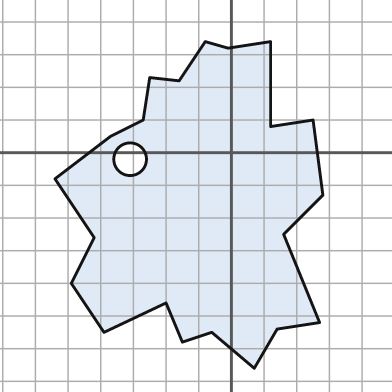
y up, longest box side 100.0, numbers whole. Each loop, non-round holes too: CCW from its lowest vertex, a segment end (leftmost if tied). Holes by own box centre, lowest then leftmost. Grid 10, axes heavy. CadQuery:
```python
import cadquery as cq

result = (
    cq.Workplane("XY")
    .moveTo(7.0, -66.0)
    .lineTo(14.0, -54.0)
    .lineTo(27.0, -52.0)
    .lineTo(16.0, -25.0)
    .lineTo(28.0, -13.0)
    .lineTo(25.0, 10.0)
    .lineTo(12.0, 8.0)
    .lineTo(12.0, 34.0)
    .lineTo(-1.0, 32.0)
    .lineTo(-8.0, 34.0)
    .lineTo(-16.0, 22.0)
    .lineTo(-25.0, 23.0)
    .lineTo(-27.0, 10.0)
    .lineTo(-37.0, 5.0)
    .lineTo(-54.0, -8.0)
    .lineTo(-42.0, -26.0)
    .lineTo(-49.0, -40.0)
    .lineTo(-39.0, -55.0)
    .lineTo(-20.0, -46.0)
    .lineTo(-15.0, -58.0)
    .lineTo(-6.0, -55.0)
    .close()
    .moveTo(-31.0, -2.0)
    .circle(5.0)
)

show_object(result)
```